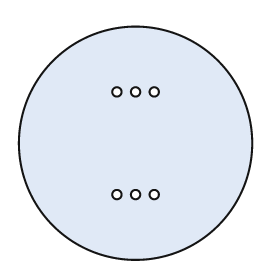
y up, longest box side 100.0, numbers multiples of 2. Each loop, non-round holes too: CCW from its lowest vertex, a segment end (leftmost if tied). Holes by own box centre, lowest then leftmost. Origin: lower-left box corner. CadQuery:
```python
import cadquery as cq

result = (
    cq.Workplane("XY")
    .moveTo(50.0, 50.0)
    .circle(50.0)
    .moveTo(42.0, 28.0)
    .circle(2.0)
    .moveTo(50.0, 28.0)
    .circle(2.0)
    .moveTo(58.0, 28.0)
    .circle(2.0)
    .moveTo(42.0, 72.0)
    .circle(2.0)
    .moveTo(50.0, 72.0)
    .circle(2.0)
    .moveTo(58.0, 72.0)
    .circle(2.0)
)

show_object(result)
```